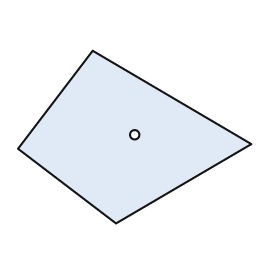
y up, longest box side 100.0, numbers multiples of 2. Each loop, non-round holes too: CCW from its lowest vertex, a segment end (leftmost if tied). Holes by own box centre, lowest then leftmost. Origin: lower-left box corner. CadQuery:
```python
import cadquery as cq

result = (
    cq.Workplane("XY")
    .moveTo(42.0, 0.0)
    .lineTo(100.0, 34.0)
    .lineTo(32.0, 74.0)
    .lineTo(0.0, 32.0)
    .close()
    .moveTo(50.0, 38.0)
    .circle(2.0)
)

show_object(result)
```